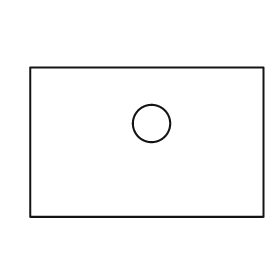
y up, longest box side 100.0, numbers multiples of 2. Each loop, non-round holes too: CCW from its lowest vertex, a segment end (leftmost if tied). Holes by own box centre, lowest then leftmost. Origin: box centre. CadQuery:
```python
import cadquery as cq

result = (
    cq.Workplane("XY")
    .moveTo(-50.0, -32.0)
    .lineTo(50.0, -32.0)
    .lineTo(50.0, 32.0)
    .lineTo(-50.0, 32.0)
    .close()
    .moveTo(2.0, 8.0)
    .circle(8.0)
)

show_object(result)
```